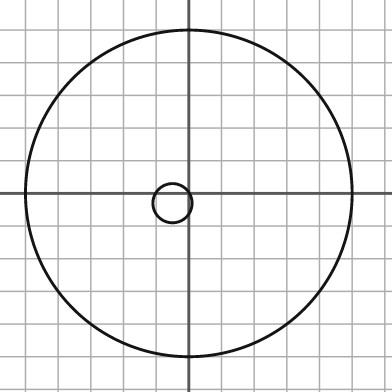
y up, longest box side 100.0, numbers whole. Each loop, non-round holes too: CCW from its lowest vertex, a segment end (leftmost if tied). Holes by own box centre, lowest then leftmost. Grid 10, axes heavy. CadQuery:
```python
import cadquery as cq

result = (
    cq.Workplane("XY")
    .moveTo(0.0, 0.0)
    .circle(50.0)
    .moveTo(-5.0, -3.0)
    .circle(6.0)
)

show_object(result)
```